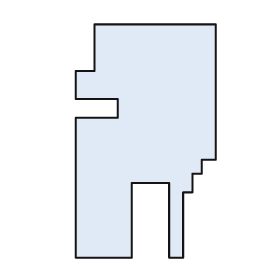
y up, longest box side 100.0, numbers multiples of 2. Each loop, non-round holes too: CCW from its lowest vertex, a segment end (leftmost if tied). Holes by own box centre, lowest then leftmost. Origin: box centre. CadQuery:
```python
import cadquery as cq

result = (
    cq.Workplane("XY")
    .moveTo(-30.0, -50.0)
    .lineTo(-6.0, -50.0)
    .lineTo(-6.0, -18.0)
    .lineTo(10.0, -18.0)
    .lineTo(10.0, -50.0)
    .lineTo(16.0, -50.0)
    .lineTo(16.0, -22.0)
    .lineTo(20.0, -22.0)
    .lineTo(20.0, -14.0)
    .lineTo(24.0, -14.0)
    .lineTo(24.0, -8.0)
    .lineTo(30.0, -8.0)
    .lineTo(30.0, 50.0)
    .lineTo(-22.0, 50.0)
    .lineTo(-22.0, 30.0)
    .lineTo(-30.0, 30.0)
    .lineTo(-30.0, 18.0)
    .lineTo(-12.0, 18.0)
    .lineTo(-12.0, 10.0)
    .lineTo(-30.0, 10.0)
    .close()
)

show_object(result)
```